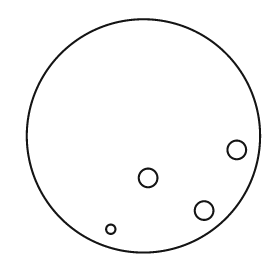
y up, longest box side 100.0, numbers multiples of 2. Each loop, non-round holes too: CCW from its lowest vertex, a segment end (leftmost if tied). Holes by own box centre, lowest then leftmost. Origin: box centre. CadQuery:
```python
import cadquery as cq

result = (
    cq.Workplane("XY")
    .moveTo(0.0, 0.0)
    .circle(50.0)
    .moveTo(-14.0, -40.0)
    .circle(2.0)
    .moveTo(26.0, -32.0)
    .circle(4.0)
    .moveTo(2.0, -18.0)
    .circle(4.0)
    .moveTo(40.0, -6.0)
    .circle(4.0)
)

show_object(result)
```